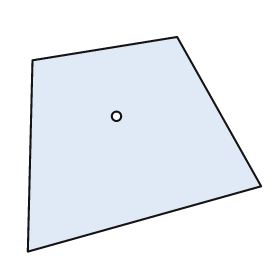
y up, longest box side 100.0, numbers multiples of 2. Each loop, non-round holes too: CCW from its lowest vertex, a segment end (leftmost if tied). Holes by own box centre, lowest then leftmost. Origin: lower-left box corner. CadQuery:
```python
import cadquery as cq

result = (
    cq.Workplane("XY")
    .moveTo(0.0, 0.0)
    .lineTo(100.0, 28.0)
    .lineTo(64.0, 92.0)
    .lineTo(2.0, 82.0)
    .close()
    .moveTo(38.0, 58.0)
    .circle(2.0)
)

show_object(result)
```